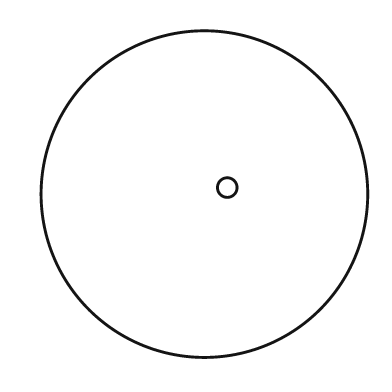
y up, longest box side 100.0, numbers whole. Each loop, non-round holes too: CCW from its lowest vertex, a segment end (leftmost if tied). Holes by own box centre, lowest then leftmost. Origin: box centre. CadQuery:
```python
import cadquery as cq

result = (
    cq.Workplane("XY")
    .moveTo(0.0, 0.0)
    .circle(50.0)
    .moveTo(7.0, 2.0)
    .circle(3.0)
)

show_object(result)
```